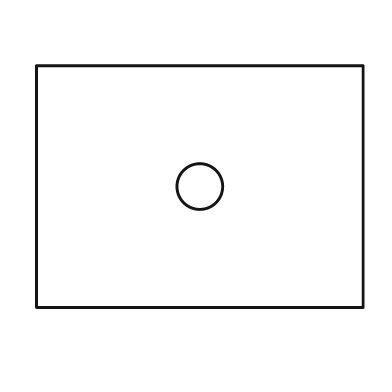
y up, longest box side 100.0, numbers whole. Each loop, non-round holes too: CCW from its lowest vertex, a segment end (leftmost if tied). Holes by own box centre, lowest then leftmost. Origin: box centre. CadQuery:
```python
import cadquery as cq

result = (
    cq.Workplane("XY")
    .moveTo(-50.0, -37.0)
    .lineTo(50.0, -37.0)
    .lineTo(50.0, 37.0)
    .lineTo(-50.0, 37.0)
    .close()
    .moveTo(0.0, 0.0)
    .circle(7.0)
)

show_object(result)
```